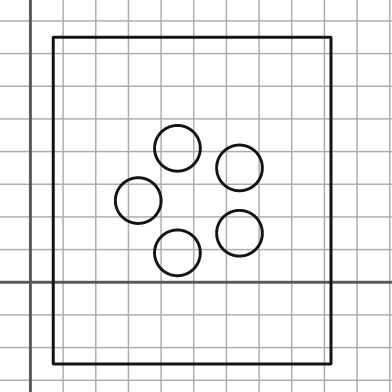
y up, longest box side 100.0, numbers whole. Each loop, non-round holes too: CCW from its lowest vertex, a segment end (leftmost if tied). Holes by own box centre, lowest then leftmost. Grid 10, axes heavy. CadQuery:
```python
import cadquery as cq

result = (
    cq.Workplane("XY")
    .moveTo(7.0, -25.0)
    .lineTo(92.0, -25.0)
    .lineTo(92.0, 75.0)
    .lineTo(7.0, 75.0)
    .close()
    .moveTo(45.0, 9.0)
    .circle(7.0)
    .moveTo(64.0, 15.0)
    .circle(7.0)
    .moveTo(33.0, 25.0)
    .circle(7.0)
    .moveTo(64.0, 35.0)
    .circle(7.0)
    .moveTo(45.0, 41.0)
    .circle(7.0)
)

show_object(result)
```